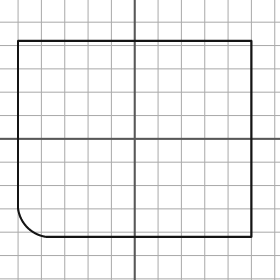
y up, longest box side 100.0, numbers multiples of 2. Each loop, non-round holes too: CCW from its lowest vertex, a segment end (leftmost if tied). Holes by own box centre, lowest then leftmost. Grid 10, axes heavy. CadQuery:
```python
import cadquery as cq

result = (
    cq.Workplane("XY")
    .moveTo(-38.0, -42.0)
    .lineTo(50.0, -42.0)
    .lineTo(50.0, 42.0)
    .lineTo(-50.0, 42.0)
    .lineTo(-50.0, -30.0)
    .threePointArc((-46.0, -38.0), (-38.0, -42.0))
    .close()
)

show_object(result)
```